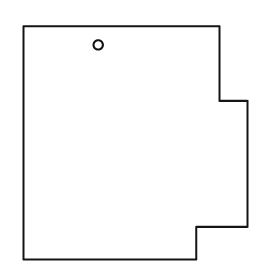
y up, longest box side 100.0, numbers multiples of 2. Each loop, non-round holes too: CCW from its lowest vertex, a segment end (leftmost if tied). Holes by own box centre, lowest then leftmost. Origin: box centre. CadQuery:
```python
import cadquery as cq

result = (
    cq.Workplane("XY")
    .moveTo(-48.0, -50.0)
    .lineTo(26.0, -50.0)
    .lineTo(26.0, -36.0)
    .lineTo(48.0, -36.0)
    .lineTo(48.0, 18.0)
    .lineTo(36.0, 18.0)
    .lineTo(36.0, 50.0)
    .lineTo(-48.0, 50.0)
    .close()
    .moveTo(-16.0, 42.0)
    .circle(2.0)
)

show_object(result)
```